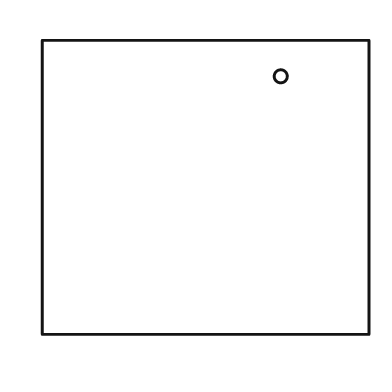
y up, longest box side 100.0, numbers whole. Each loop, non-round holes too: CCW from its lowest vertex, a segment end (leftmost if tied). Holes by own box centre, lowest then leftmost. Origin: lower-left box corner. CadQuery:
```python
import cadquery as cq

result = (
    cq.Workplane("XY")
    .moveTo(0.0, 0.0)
    .lineTo(100.0, 0.0)
    .lineTo(100.0, 90.0)
    .lineTo(0.0, 90.0)
    .close()
    .moveTo(73.0, 79.0)
    .circle(2.0)
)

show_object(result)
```